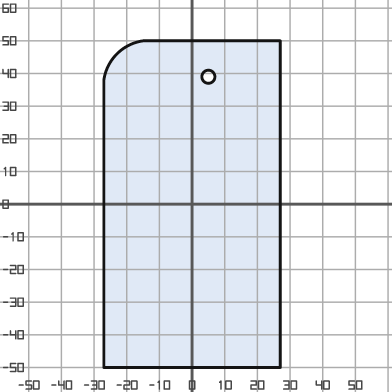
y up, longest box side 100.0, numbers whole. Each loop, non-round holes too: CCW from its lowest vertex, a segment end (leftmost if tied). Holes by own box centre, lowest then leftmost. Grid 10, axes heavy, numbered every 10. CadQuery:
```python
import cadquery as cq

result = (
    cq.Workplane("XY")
    .moveTo(-27.0, -50.0)
    .lineTo(27.0, -50.0)
    .lineTo(27.0, 50.0)
    .lineTo(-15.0, 50.0)
    .threePointArc((-23.0, 46.0), (-27.0, 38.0))
    .close()
    .moveTo(5.0, 39.0)
    .circle(2.0)
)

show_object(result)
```